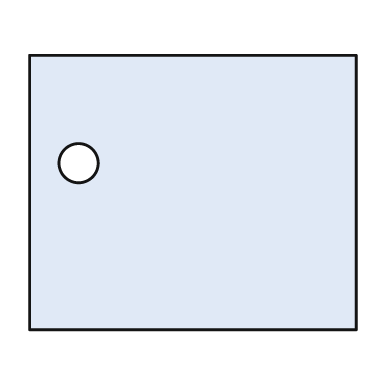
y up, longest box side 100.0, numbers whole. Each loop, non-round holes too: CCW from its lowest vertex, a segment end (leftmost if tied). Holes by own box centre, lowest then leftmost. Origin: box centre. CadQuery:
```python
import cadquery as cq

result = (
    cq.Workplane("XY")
    .moveTo(-50.0, -42.0)
    .lineTo(50.0, -42.0)
    .lineTo(50.0, 42.0)
    .lineTo(-50.0, 42.0)
    .close()
    .moveTo(-35.0, 9.0)
    .circle(6.0)
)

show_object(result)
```